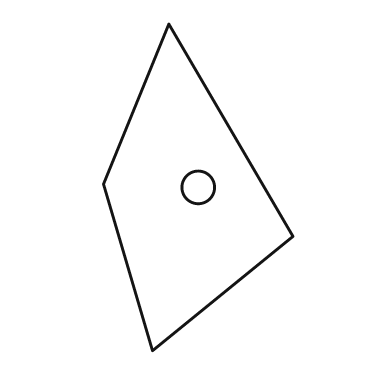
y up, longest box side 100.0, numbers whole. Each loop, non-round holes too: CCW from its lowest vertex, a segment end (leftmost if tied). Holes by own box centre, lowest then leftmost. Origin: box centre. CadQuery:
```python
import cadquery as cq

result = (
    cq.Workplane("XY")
    .moveTo(-14.0, -50.0)
    .lineTo(29.0, -15.0)
    .lineTo(-9.0, 50.0)
    .lineTo(-29.0, 1.0)
    .close()
    .moveTo(0.0, 0.0)
    .circle(5.0)
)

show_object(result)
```